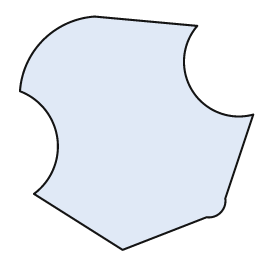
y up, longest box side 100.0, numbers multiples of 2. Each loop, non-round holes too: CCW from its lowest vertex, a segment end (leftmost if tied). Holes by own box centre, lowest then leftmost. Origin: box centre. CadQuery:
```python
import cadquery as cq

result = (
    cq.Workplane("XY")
    .moveTo(-6.0, -50.0)
    .lineTo(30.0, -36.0)
    .threePointArc((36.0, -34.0), (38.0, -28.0))
    .lineTo(50.0, 8.0)
    .threePointArc((24.0, 18.0), (26.0, 46.0))
    .lineTo(-18.0, 50.0)
    .threePointArc((-40.0, 40.0), (-50.0, 18.0))
    .threePointArc((-34.0, -2.0), (-44.0, -26.0))
    .close()
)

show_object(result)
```